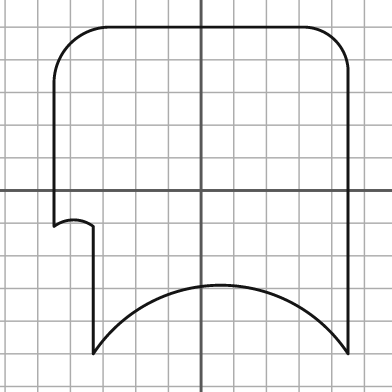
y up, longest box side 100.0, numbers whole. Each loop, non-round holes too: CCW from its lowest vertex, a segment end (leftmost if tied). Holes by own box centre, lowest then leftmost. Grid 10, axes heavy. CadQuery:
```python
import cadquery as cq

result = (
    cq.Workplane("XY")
    .moveTo(-33.0, -50.0)
    .threePointArc((6.0, -29.0), (45.0, -50.0))
    .lineTo(45.0, 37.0)
    .threePointArc((41.0, 46.0), (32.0, 50.0))
    .lineTo(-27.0, 50.0)
    .threePointArc((-40.0, 45.0), (-45.0, 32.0))
    .lineTo(-45.0, -11.0)
    .threePointArc((-39.0, -9.0), (-33.0, -11.0))
    .close()
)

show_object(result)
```